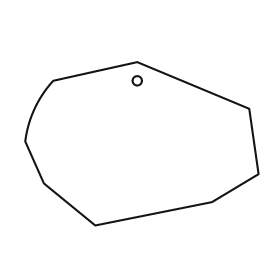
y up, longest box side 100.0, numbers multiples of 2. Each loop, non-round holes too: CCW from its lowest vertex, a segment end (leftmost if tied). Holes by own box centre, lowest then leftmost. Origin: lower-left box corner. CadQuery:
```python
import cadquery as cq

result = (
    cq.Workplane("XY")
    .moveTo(30.0, 0.0)
    .lineTo(80.0, 10.0)
    .lineTo(100.0, 22.0)
    .lineTo(96.0, 50.0)
    .lineTo(48.0, 70.0)
    .lineTo(12.0, 62.0)
    .threePointArc((4.0, 50.0), (0.0, 36.0))
    .lineTo(8.0, 18.0)
    .close()
    .moveTo(48.0, 62.0)
    .circle(2.0)
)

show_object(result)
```